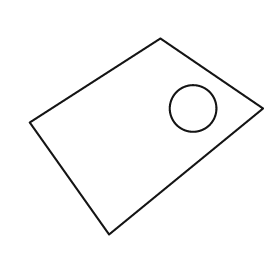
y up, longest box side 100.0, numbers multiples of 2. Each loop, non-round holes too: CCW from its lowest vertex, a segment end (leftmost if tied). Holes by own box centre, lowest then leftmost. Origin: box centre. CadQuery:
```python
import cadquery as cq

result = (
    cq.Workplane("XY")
    .moveTo(-16.0, -42.0)
    .lineTo(50.0, 12.0)
    .lineTo(6.0, 42.0)
    .lineTo(-50.0, 6.0)
    .close()
    .moveTo(20.0, 12.0)
    .circle(10.0)
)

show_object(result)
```